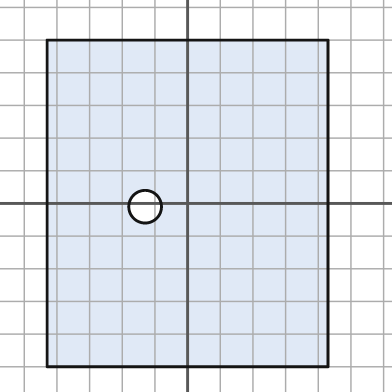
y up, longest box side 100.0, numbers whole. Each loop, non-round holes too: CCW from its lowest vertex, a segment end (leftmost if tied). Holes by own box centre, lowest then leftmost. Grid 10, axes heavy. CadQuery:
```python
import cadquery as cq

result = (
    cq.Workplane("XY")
    .moveTo(-43.0, -50.0)
    .lineTo(43.0, -50.0)
    .lineTo(43.0, 50.0)
    .lineTo(-43.0, 50.0)
    .close()
    .moveTo(-13.0, -1.0)
    .circle(5.0)
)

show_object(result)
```